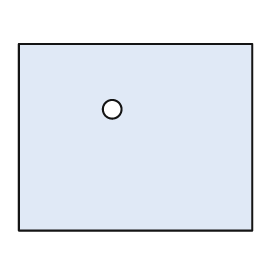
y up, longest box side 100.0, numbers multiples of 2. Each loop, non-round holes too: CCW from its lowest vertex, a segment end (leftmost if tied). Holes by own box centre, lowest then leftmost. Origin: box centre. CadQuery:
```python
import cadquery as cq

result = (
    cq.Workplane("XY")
    .moveTo(-50.0, -40.0)
    .lineTo(50.0, -40.0)
    .lineTo(50.0, 40.0)
    .lineTo(-50.0, 40.0)
    .close()
    .moveTo(-10.0, 12.0)
    .circle(4.0)
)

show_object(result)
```